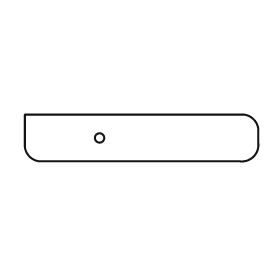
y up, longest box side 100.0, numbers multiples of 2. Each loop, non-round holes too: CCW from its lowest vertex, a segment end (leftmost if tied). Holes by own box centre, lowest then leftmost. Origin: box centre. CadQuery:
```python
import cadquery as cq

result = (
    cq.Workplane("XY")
    .moveTo(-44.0, -10.0)
    .lineTo(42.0, -10.0)
    .threePointArc((48.0, -8.0), (50.0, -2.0))
    .lineTo(50.0, 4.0)
    .threePointArc((48.0, 8.0), (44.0, 10.0))
    .lineTo(-50.0, 10.0)
    .lineTo(-50.0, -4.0)
    .threePointArc((-48.0, -8.0), (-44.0, -10.0))
    .close()
    .moveTo(-18.0, 0.0)
    .circle(2.0)
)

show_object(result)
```